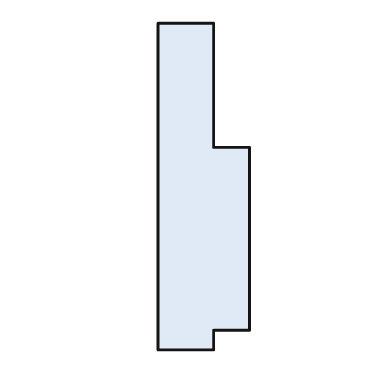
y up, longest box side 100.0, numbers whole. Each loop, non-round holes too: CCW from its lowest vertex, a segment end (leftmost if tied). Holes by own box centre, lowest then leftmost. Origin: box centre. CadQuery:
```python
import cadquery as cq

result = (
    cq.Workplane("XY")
    .moveTo(-14.0, -50.0)
    .lineTo(3.0, -50.0)
    .lineTo(3.0, -44.0)
    .lineTo(14.0, -44.0)
    .lineTo(14.0, 12.0)
    .lineTo(3.0, 12.0)
    .lineTo(3.0, 50.0)
    .lineTo(-14.0, 50.0)
    .close()
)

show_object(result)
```